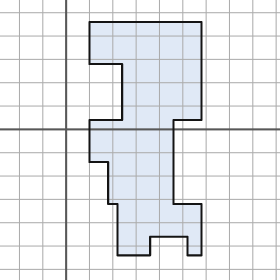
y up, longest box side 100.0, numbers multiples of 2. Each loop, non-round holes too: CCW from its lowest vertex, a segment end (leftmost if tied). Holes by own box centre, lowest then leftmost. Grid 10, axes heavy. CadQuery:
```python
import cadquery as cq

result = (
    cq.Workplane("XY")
    .moveTo(22.0, -54.0)
    .lineTo(36.0, -54.0)
    .lineTo(36.0, -46.0)
    .lineTo(52.0, -46.0)
    .lineTo(52.0, -54.0)
    .lineTo(58.0, -54.0)
    .lineTo(58.0, -32.0)
    .lineTo(46.0, -32.0)
    .lineTo(46.0, 4.0)
    .lineTo(58.0, 4.0)
    .lineTo(58.0, 46.0)
    .lineTo(10.0, 46.0)
    .lineTo(10.0, 28.0)
    .lineTo(24.0, 28.0)
    .lineTo(24.0, 4.0)
    .lineTo(10.0, 4.0)
    .lineTo(10.0, -14.0)
    .lineTo(18.0, -14.0)
    .lineTo(18.0, -32.0)
    .lineTo(22.0, -32.0)
    .close()
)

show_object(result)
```